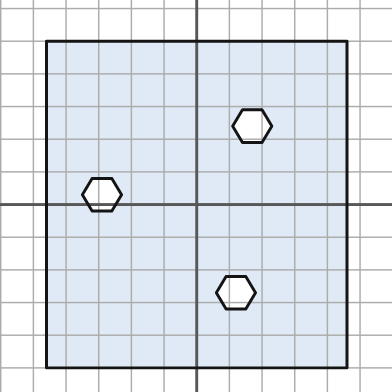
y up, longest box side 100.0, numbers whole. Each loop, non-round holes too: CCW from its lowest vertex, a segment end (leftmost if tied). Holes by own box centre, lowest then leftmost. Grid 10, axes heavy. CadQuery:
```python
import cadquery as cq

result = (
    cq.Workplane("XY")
    .moveTo(-46.0, -50.0)
    .lineTo(46.0, -50.0)
    .lineTo(46.0, 50.0)
    .lineTo(-46.0, 50.0)
    .close()
    .moveTo(9.0, -32.0)
    .lineTo(15.0, -32.0)
    .lineTo(18.0, -27.0)
    .lineTo(15.0, -22.0)
    .lineTo(9.0, -22.0)
    .lineTo(6.0, -27.0)
    .close()
    .moveTo(-32.0, -2.0)
    .lineTo(-26.0, -2.0)
    .lineTo(-23.0, 3.0)
    .lineTo(-26.0, 8.0)
    .lineTo(-32.0, 8.0)
    .lineTo(-35.0, 3.0)
    .close()
    .moveTo(14.0, 19.0)
    .lineTo(20.0, 19.0)
    .lineTo(23.0, 24.0)
    .lineTo(20.0, 29.0)
    .lineTo(14.0, 29.0)
    .lineTo(11.0, 24.0)
    .close()
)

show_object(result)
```